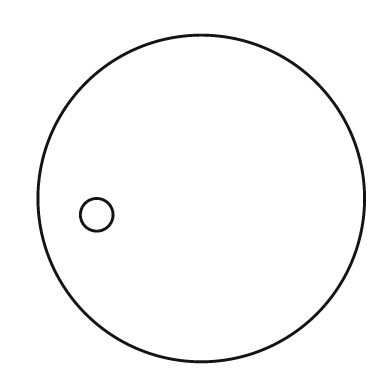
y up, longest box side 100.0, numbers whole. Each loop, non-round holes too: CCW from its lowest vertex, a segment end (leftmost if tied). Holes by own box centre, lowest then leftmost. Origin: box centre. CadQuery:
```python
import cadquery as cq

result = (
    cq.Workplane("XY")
    .moveTo(0.0, 0.0)
    .circle(50.0)
    .moveTo(-32.0, -5.0)
    .circle(5.0)
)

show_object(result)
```